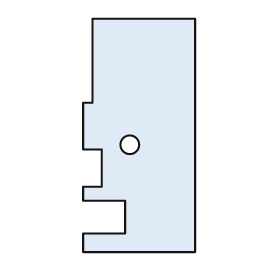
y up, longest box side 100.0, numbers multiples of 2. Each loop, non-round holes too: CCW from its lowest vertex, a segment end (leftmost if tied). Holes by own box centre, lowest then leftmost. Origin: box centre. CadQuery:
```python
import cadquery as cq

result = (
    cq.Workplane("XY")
    .moveTo(-24.0, -50.0)
    .lineTo(24.0, -50.0)
    .lineTo(24.0, 50.0)
    .lineTo(-20.0, 50.0)
    .lineTo(-20.0, 14.0)
    .lineTo(-24.0, 14.0)
    .lineTo(-24.0, -6.0)
    .lineTo(-16.0, -6.0)
    .lineTo(-16.0, -22.0)
    .lineTo(-24.0, -22.0)
    .lineTo(-24.0, -28.0)
    .lineTo(-6.0, -28.0)
    .lineTo(-6.0, -42.0)
    .lineTo(-24.0, -42.0)
    .close()
    .moveTo(-4.0, -4.0)
    .circle(4.0)
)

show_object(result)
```